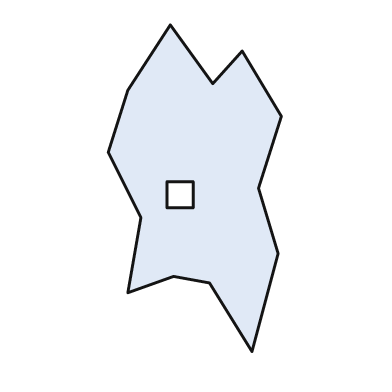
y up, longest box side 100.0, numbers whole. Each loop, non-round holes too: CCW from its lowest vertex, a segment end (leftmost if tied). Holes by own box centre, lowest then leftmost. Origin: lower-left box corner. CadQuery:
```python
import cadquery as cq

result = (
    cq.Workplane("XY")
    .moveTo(44.0, 0.0)
    .lineTo(52.0, 30.0)
    .lineTo(46.0, 50.0)
    .lineTo(53.0, 72.0)
    .lineTo(41.0, 92.0)
    .lineTo(32.0, 82.0)
    .lineTo(19.0, 100.0)
    .lineTo(6.0, 80.0)
    .lineTo(0.0, 61.0)
    .lineTo(10.0, 41.0)
    .lineTo(6.0, 18.0)
    .lineTo(20.0, 23.0)
    .lineTo(31.0, 21.0)
    .close()
    .moveTo(18.0, 44.0)
    .lineTo(26.0, 44.0)
    .lineTo(26.0, 52.0)
    .lineTo(18.0, 52.0)
    .close()
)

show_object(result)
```